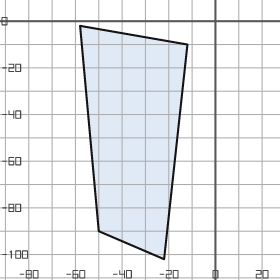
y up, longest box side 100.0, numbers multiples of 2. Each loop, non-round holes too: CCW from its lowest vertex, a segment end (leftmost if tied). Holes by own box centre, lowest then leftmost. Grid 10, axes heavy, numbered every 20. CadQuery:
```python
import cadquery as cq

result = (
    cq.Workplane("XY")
    .moveTo(-22.0, -102.0)
    .lineTo(-12.0, -10.0)
    .lineTo(-58.0, -2.0)
    .lineTo(-50.0, -90.0)
    .close()
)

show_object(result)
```